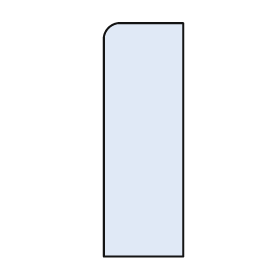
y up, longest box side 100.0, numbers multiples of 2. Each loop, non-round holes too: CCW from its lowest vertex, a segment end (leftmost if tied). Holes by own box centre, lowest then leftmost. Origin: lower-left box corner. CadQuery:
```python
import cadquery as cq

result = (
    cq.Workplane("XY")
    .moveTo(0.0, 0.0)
    .lineTo(34.0, 0.0)
    .lineTo(34.0, 100.0)
    .lineTo(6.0, 100.0)
    .threePointArc((2.0, 98.0), (0.0, 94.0))
    .close()
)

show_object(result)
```